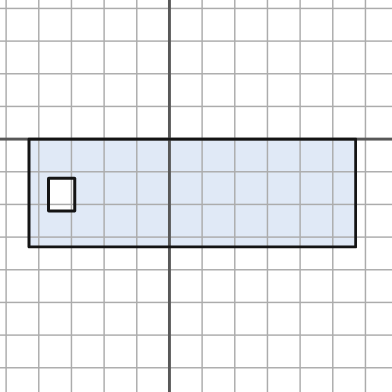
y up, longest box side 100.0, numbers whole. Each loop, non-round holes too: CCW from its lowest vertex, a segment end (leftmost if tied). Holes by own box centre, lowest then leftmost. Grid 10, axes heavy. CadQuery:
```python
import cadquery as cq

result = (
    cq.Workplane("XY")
    .moveTo(-43.0, -33.0)
    .lineTo(57.0, -33.0)
    .lineTo(57.0, 0.0)
    .lineTo(-43.0, 0.0)
    .close()
    .moveTo(-37.0, -22.0)
    .lineTo(-29.0, -22.0)
    .lineTo(-29.0, -12.0)
    .lineTo(-37.0, -12.0)
    .close()
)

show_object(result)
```